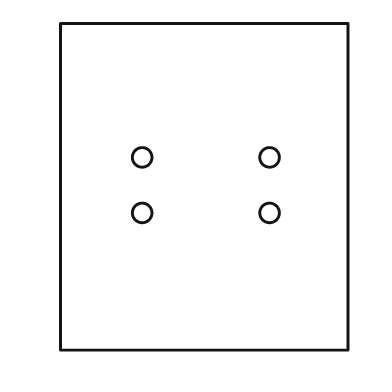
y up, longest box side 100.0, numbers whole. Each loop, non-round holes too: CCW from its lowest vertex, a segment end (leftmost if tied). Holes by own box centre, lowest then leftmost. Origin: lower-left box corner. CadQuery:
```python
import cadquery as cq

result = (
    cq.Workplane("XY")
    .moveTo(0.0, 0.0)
    .lineTo(88.0, 0.0)
    .lineTo(88.0, 100.0)
    .lineTo(0.0, 100.0)
    .close()
    .moveTo(25.0, 42.0)
    .circle(3.0)
    .moveTo(64.0, 42.0)
    .circle(3.0)
    .moveTo(25.0, 59.0)
    .circle(3.0)
    .moveTo(64.0, 59.0)
    .circle(3.0)
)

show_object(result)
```